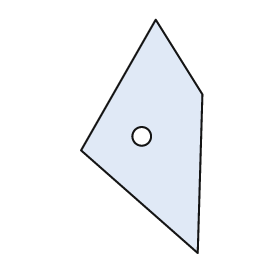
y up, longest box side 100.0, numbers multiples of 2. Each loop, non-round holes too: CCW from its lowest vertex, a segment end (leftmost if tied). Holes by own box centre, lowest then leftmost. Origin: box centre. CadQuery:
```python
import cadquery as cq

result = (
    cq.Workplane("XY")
    .moveTo(24.0, -50.0)
    .lineTo(26.0, 18.0)
    .lineTo(6.0, 50.0)
    .lineTo(-26.0, -6.0)
    .close()
    .moveTo(0.0, 0.0)
    .circle(4.0)
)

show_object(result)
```